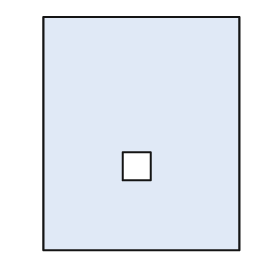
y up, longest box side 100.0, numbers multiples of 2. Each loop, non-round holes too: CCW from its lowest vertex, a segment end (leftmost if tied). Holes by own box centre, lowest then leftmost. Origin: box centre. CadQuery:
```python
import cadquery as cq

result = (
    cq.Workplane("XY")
    .moveTo(-42.0, -50.0)
    .lineTo(42.0, -50.0)
    .lineTo(42.0, 50.0)
    .lineTo(-42.0, 50.0)
    .close()
    .moveTo(-8.0, -20.0)
    .lineTo(4.0, -20.0)
    .lineTo(4.0, -8.0)
    .lineTo(-8.0, -8.0)
    .close()
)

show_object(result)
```